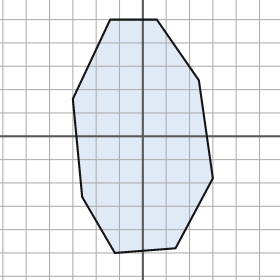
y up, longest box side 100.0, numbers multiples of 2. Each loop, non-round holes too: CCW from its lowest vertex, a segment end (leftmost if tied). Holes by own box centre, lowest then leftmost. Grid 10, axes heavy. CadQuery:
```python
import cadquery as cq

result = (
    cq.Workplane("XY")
    .moveTo(-12.0, -50.0)
    .lineTo(14.0, -48.0)
    .lineTo(30.0, -18.0)
    .lineTo(24.0, 24.0)
    .lineTo(6.0, 50.0)
    .lineTo(-14.0, 50.0)
    .lineTo(-30.0, 16.0)
    .lineTo(-26.0, -26.0)
    .close()
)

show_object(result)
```